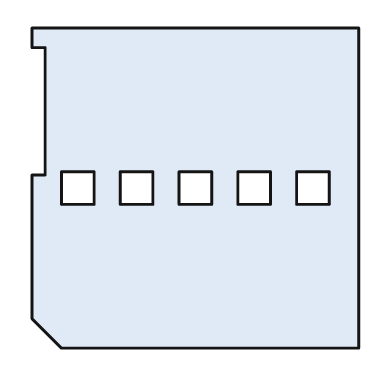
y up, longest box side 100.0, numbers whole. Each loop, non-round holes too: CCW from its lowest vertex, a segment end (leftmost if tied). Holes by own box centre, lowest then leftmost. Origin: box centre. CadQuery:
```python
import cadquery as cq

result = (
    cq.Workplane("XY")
    .moveTo(-41.0, -49.0)
    .lineTo(50.0, -49.0)
    .lineTo(50.0, 49.0)
    .lineTo(-50.0, 49.0)
    .lineTo(-50.0, 43.0)
    .lineTo(-46.0, 43.0)
    .lineTo(-46.0, 4.0)
    .lineTo(-50.0, 4.0)
    .lineTo(-50.0, -40.0)
    .close()
    .moveTo(-41.0, -5.0)
    .lineTo(-31.0, -5.0)
    .lineTo(-31.0, 5.0)
    .lineTo(-41.0, 5.0)
    .close()
    .moveTo(-23.0, -5.0)
    .lineTo(-13.0, -5.0)
    .lineTo(-13.0, 5.0)
    .lineTo(-23.0, 5.0)
    .close()
    .moveTo(-5.0, -5.0)
    .lineTo(5.0, -5.0)
    .lineTo(5.0, 5.0)
    .lineTo(-5.0, 5.0)
    .close()
    .moveTo(13.0, -5.0)
    .lineTo(23.0, -5.0)
    .lineTo(23.0, 5.0)
    .lineTo(13.0, 5.0)
    .close()
    .moveTo(31.0, -5.0)
    .lineTo(41.0, -5.0)
    .lineTo(41.0, 5.0)
    .lineTo(31.0, 5.0)
    .close()
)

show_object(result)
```